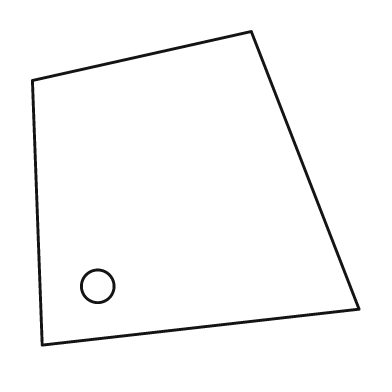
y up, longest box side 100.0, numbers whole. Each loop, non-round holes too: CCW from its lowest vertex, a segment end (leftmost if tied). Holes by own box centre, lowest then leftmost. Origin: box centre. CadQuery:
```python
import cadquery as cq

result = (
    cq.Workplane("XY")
    .moveTo(-47.0, -48.0)
    .lineTo(50.0, -37.0)
    .lineTo(17.0, 48.0)
    .lineTo(-50.0, 33.0)
    .close()
    .moveTo(-30.0, -30.0)
    .circle(5.0)
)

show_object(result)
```